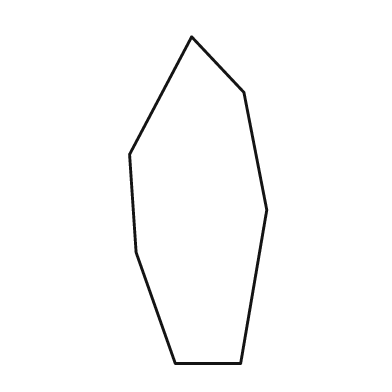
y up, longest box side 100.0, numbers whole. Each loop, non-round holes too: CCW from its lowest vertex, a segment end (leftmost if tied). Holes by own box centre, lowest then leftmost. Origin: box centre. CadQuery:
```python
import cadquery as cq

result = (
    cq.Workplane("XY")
    .moveTo(-7.0, -50.0)
    .lineTo(13.0, -50.0)
    .lineTo(21.0, -3.0)
    .lineTo(14.0, 33.0)
    .lineTo(-2.0, 50.0)
    .lineTo(-21.0, 14.0)
    .lineTo(-19.0, -16.0)
    .close()
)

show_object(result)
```